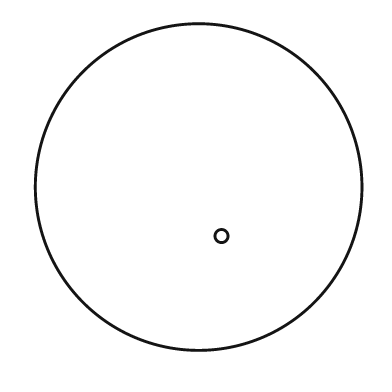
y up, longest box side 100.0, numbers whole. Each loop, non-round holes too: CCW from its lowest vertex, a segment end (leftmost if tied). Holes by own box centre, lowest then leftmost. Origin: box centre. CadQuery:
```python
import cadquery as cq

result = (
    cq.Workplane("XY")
    .moveTo(0.0, 0.0)
    .circle(50.0)
    .moveTo(7.0, -15.0)
    .circle(2.0)
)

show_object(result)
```